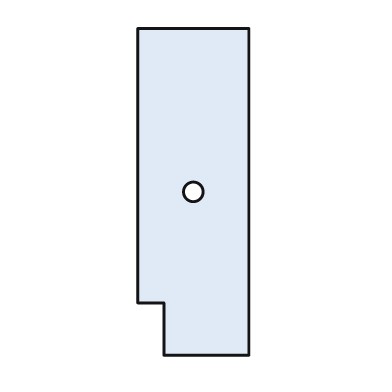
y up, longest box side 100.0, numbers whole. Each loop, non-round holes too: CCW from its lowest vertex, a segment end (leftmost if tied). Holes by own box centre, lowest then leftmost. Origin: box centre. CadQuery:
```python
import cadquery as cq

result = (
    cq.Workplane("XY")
    .moveTo(-9.0, -50.0)
    .lineTo(17.0, -50.0)
    .lineTo(17.0, 50.0)
    .lineTo(-17.0, 50.0)
    .lineTo(-17.0, -34.0)
    .lineTo(-9.0, -34.0)
    .close()
    .moveTo(0.0, 0.0)
    .circle(3.0)
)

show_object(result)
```